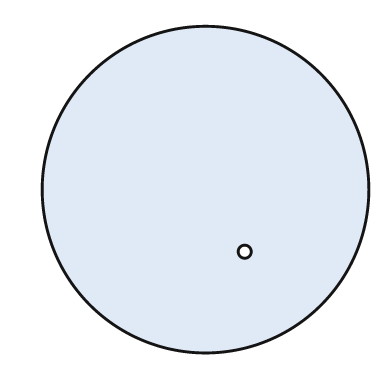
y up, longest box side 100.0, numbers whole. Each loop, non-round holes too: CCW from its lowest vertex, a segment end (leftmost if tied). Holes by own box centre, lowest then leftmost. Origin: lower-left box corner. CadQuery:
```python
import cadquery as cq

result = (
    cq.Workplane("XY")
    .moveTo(50.0, 50.0)
    .circle(50.0)
    .moveTo(62.0, 31.0)
    .circle(2.0)
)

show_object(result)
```